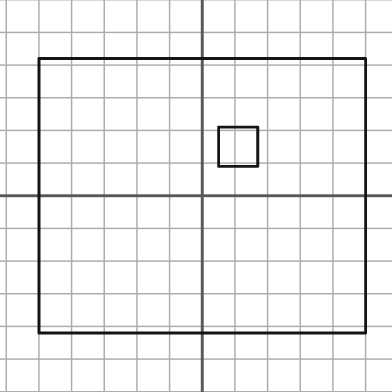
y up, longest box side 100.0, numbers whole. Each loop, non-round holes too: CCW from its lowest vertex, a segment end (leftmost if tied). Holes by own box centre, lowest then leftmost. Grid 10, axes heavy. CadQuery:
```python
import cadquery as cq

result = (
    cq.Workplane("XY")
    .moveTo(-50.0, -42.0)
    .lineTo(50.0, -42.0)
    .lineTo(50.0, 42.0)
    .lineTo(-50.0, 42.0)
    .close()
    .moveTo(5.0, 9.0)
    .lineTo(17.0, 9.0)
    .lineTo(17.0, 21.0)
    .lineTo(5.0, 21.0)
    .close()
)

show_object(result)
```